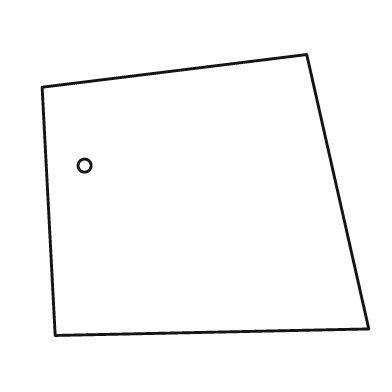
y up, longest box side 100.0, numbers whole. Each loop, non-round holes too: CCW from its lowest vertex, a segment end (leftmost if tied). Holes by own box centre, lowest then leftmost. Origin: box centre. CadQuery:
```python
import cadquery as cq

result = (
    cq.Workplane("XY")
    .moveTo(-46.0, -43.0)
    .lineTo(50.0, -41.0)
    .lineTo(31.0, 43.0)
    .lineTo(-50.0, 33.0)
    .close()
    .moveTo(-37.0, 9.0)
    .circle(2.0)
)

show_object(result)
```